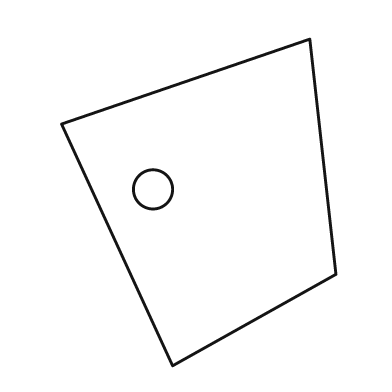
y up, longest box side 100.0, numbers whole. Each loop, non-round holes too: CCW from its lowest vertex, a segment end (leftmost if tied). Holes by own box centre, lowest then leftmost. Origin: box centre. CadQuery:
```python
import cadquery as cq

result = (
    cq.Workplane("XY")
    .moveTo(-8.0, -50.0)
    .lineTo(42.0, -22.0)
    .lineTo(34.0, 50.0)
    .lineTo(-42.0, 24.0)
    .close()
    .moveTo(-14.0, 4.0)
    .circle(6.0)
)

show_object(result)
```